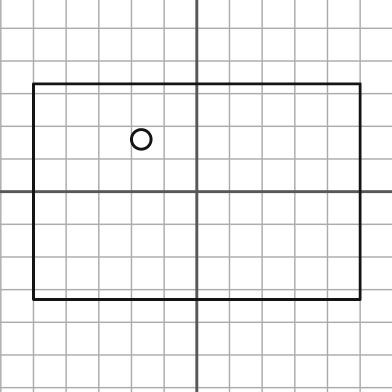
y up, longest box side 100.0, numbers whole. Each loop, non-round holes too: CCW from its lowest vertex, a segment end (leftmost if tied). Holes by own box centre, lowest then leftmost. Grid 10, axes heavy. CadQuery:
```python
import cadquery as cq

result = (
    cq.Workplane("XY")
    .moveTo(-50.0, -33.0)
    .lineTo(50.0, -33.0)
    .lineTo(50.0, 33.0)
    .lineTo(-50.0, 33.0)
    .close()
    .moveTo(-17.0, 16.0)
    .circle(3.0)
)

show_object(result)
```